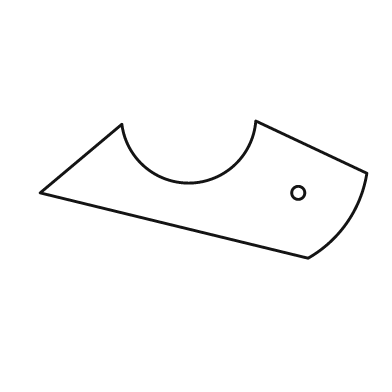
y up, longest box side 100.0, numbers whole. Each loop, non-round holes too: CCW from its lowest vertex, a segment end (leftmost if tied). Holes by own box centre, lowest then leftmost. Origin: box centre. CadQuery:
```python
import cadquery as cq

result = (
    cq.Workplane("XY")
    .moveTo(32.0, -21.0)
    .threePointArc((44.0, -10.0), (50.0, 5.0))
    .lineTo(16.0, 21.0)
    .threePointArc((-4.0, 2.0), (-25.0, 20.0))
    .lineTo(-50.0, -1.0)
    .close()
    .moveTo(29.0, -1.0)
    .circle(2.0)
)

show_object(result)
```